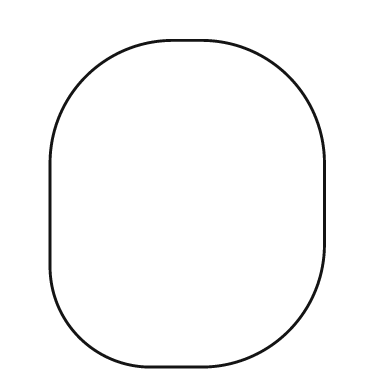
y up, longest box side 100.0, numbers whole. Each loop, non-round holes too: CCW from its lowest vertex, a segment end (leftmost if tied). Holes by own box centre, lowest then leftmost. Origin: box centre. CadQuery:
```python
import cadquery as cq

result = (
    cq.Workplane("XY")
    .moveTo(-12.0, -50.0)
    .lineTo(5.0, -50.0)
    .threePointArc((31.0, -39.0), (42.0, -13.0))
    .lineTo(42.0, 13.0)
    .threePointArc((31.0, 39.0), (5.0, 50.0))
    .lineTo(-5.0, 50.0)
    .threePointArc((-31.0, 39.0), (-42.0, 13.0))
    .lineTo(-42.0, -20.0)
    .threePointArc((-33.0, -41.0), (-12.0, -50.0))
    .close()
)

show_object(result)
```